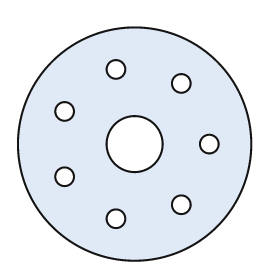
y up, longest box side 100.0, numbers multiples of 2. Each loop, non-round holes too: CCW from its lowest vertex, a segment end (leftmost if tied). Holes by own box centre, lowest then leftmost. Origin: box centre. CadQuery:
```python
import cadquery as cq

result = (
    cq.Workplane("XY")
    .moveTo(0.0, 0.0)
    .circle(50.0)
    .moveTo(-8.0, -32.0)
    .circle(4.0)
    .moveTo(20.0, -26.0)
    .circle(4.0)
    .moveTo(-30.0, -14.0)
    .circle(4.0)
    .moveTo(0.0, 0.0)
    .circle(12.0)
    .moveTo(32.0, 0.0)
    .circle(4.0)
    .moveTo(-30.0, 14.0)
    .circle(4.0)
    .moveTo(20.0, 26.0)
    .circle(4.0)
    .moveTo(-8.0, 32.0)
    .circle(4.0)
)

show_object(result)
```